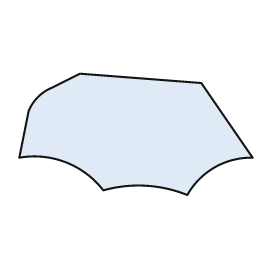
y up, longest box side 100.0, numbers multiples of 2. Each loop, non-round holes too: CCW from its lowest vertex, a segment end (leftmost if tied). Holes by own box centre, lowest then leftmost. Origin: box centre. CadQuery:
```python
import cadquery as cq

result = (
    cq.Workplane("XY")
    .moveTo(22.0, -26.0)
    .threePointArc((34.0, -14.0), (50.0, -10.0))
    .lineTo(28.0, 22.0)
    .lineTo(-24.0, 26.0)
    .lineTo(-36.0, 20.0)
    .threePointArc((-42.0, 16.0), (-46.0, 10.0))
    .lineTo(-50.0, -10.0)
    .threePointArc((-30.0, -12.0), (-14.0, -24.0))
    .threePointArc((4.0, -22.0), (22.0, -26.0))
    .close()
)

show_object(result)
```